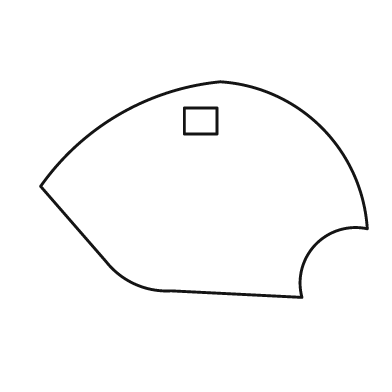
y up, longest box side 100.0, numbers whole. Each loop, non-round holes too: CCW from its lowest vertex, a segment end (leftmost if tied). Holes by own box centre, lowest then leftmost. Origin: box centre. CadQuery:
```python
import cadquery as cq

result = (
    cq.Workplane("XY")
    .moveTo(30.0, -33.0)
    .threePointArc((34.0, -17.0), (50.0, -12.0))
    .threePointArc((36.0, 19.0), (5.0, 33.0))
    .threePointArc((-26.0, 23.0), (-50.0, 1.0))
    .lineTo(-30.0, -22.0)
    .threePointArc((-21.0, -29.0), (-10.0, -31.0))
    .close()
    .moveTo(-6.0, 17.0)
    .lineTo(4.0, 17.0)
    .lineTo(4.0, 25.0)
    .lineTo(-6.0, 25.0)
    .close()
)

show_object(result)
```